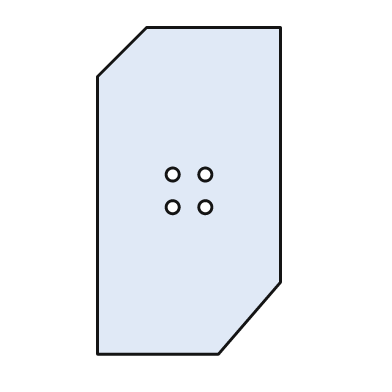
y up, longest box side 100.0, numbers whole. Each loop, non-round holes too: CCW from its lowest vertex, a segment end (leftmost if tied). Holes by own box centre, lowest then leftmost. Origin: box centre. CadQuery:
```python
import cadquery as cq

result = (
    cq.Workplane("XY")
    .moveTo(-28.0, -50.0)
    .lineTo(9.0, -50.0)
    .lineTo(28.0, -28.0)
    .lineTo(28.0, 50.0)
    .lineTo(-13.0, 50.0)
    .lineTo(-28.0, 35.0)
    .close()
    .moveTo(-5.0, -5.0)
    .circle(2.0)
    .moveTo(5.0, -5.0)
    .circle(2.0)
    .moveTo(-5.0, 5.0)
    .circle(2.0)
    .moveTo(5.0, 5.0)
    .circle(2.0)
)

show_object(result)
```